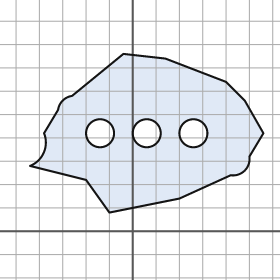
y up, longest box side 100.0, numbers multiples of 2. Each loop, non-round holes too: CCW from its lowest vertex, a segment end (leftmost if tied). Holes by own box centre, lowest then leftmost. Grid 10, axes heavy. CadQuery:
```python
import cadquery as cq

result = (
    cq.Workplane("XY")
    .moveTo(-10.0, 8.0)
    .lineTo(20.0, 14.0)
    .lineTo(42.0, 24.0)
    .threePointArc((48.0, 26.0), (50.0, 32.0))
    .lineTo(56.0, 42.0)
    .lineTo(48.0, 56.0)
    .lineTo(40.0, 64.0)
    .lineTo(14.0, 74.0)
    .lineTo(-4.0, 76.0)
    .lineTo(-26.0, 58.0)
    .threePointArc((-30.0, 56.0), (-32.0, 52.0))
    .lineTo(-38.0, 42.0)
    .threePointArc((-38.0, 34.0), (-44.0, 28.0))
    .lineTo(-20.0, 22.0)
    .close()
    .moveTo(-14.0, 42.0)
    .circle(6.0)
    .moveTo(6.0, 42.0)
    .circle(6.0)
    .moveTo(26.0, 42.0)
    .circle(6.0)
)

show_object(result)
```